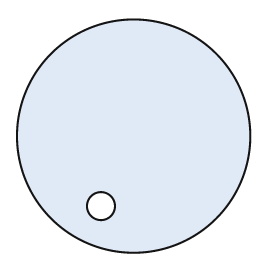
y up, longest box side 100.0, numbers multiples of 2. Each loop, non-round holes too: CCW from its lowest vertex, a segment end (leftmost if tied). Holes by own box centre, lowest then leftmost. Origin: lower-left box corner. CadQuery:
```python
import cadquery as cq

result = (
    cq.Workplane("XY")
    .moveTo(50.0, 50.0)
    .circle(50.0)
    .moveTo(36.0, 20.0)
    .circle(6.0)
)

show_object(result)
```